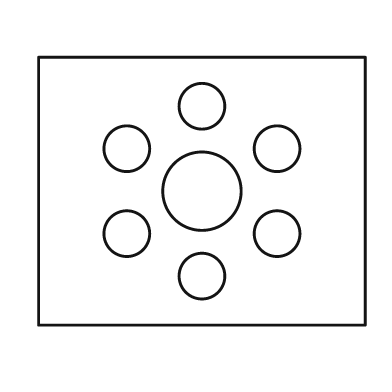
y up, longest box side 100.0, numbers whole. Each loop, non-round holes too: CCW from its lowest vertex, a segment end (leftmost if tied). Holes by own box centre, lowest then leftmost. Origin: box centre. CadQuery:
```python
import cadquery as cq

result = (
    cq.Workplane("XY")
    .moveTo(-50.0, -41.0)
    .lineTo(50.0, -41.0)
    .lineTo(50.0, 41.0)
    .lineTo(-50.0, 41.0)
    .close()
    .moveTo(0.0, -26.0)
    .circle(7.0)
    .moveTo(-23.0, -13.0)
    .circle(7.0)
    .moveTo(23.0, -13.0)
    .circle(7.0)
    .moveTo(0.0, 0.0)
    .circle(12.0)
    .moveTo(-23.0, 13.0)
    .circle(7.0)
    .moveTo(23.0, 13.0)
    .circle(7.0)
    .moveTo(0.0, 26.0)
    .circle(7.0)
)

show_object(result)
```